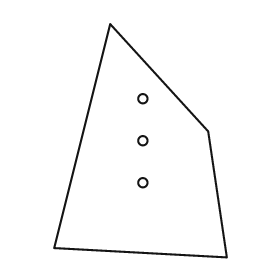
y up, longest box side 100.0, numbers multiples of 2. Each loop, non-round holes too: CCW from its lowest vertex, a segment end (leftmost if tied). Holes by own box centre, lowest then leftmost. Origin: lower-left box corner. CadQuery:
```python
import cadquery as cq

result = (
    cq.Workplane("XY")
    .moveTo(74.0, 0.0)
    .lineTo(66.0, 54.0)
    .lineTo(24.0, 100.0)
    .lineTo(0.0, 4.0)
    .close()
    .moveTo(38.0, 32.0)
    .circle(2.0)
    .moveTo(38.0, 50.0)
    .circle(2.0)
    .moveTo(38.0, 68.0)
    .circle(2.0)
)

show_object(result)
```